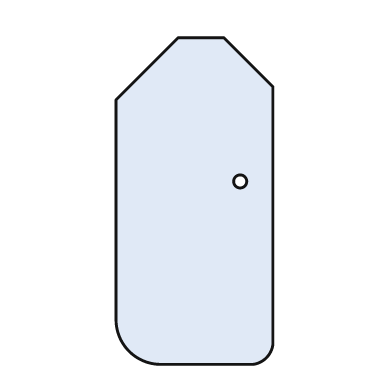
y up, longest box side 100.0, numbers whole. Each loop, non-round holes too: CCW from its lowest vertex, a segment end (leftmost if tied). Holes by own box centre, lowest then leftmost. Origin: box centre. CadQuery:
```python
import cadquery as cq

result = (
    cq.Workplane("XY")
    .moveTo(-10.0, -50.0)
    .lineTo(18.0, -50.0)
    .threePointArc((22.0, -48.0), (24.0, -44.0))
    .lineTo(24.0, 35.0)
    .lineTo(9.0, 50.0)
    .lineTo(-5.0, 50.0)
    .lineTo(-24.0, 31.0)
    .lineTo(-24.0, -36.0)
    .threePointArc((-20.0, -46.0), (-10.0, -50.0))
    .close()
    .moveTo(14.0, 6.0)
    .circle(2.0)
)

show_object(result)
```